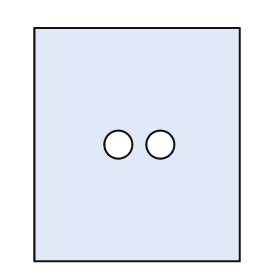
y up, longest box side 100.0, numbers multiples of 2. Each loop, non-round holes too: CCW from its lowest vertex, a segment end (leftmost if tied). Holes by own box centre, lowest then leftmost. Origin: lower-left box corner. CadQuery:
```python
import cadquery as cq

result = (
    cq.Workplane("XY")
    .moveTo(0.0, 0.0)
    .lineTo(88.0, 0.0)
    .lineTo(88.0, 100.0)
    .lineTo(0.0, 100.0)
    .close()
    .moveTo(36.0, 50.0)
    .circle(6.0)
    .moveTo(54.0, 50.0)
    .circle(6.0)
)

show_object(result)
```